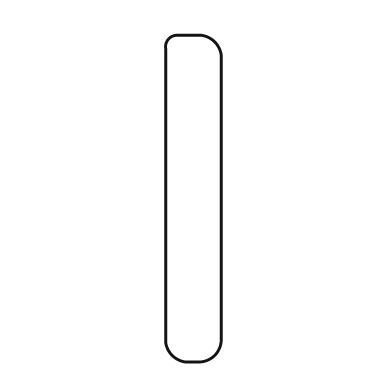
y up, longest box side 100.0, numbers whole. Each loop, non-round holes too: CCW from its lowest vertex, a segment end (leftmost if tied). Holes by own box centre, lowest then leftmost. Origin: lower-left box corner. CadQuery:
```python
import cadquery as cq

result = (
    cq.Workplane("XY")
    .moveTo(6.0, 0.0)
    .lineTo(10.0, 0.0)
    .threePointArc((15.0, 2.0), (17.0, 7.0))
    .lineTo(17.0, 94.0)
    .threePointArc((15.0, 98.0), (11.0, 100.0))
    .lineTo(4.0, 100.0)
    .threePointArc((1.0, 99.0), (0.0, 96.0))
    .lineTo(0.0, 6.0)
    .threePointArc((2.0, 2.0), (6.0, 0.0))
    .close()
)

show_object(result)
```